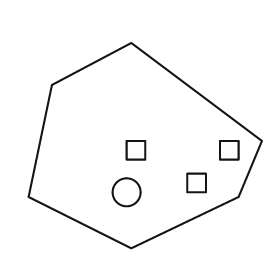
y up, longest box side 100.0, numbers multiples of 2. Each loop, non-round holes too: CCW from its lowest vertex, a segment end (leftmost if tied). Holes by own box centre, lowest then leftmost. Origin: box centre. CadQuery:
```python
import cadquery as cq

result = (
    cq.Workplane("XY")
    .moveTo(-6.0, -44.0)
    .lineTo(40.0, -22.0)
    .lineTo(50.0, 2.0)
    .lineTo(-6.0, 44.0)
    .lineTo(-40.0, 26.0)
    .lineTo(-50.0, -22.0)
    .close()
    .moveTo(-8.0, -20.0)
    .circle(6.0)
    .moveTo(18.0, -20.0)
    .lineTo(26.0, -20.0)
    .lineTo(26.0, -12.0)
    .lineTo(18.0, -12.0)
    .close()
    .moveTo(-8.0, -6.0)
    .lineTo(0.0, -6.0)
    .lineTo(0.0, 2.0)
    .lineTo(-8.0, 2.0)
    .close()
    .moveTo(32.0, -6.0)
    .lineTo(40.0, -6.0)
    .lineTo(40.0, 2.0)
    .lineTo(32.0, 2.0)
    .close()
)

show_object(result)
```